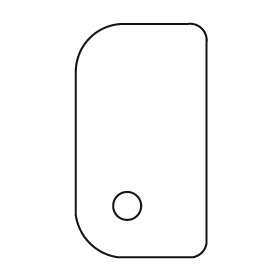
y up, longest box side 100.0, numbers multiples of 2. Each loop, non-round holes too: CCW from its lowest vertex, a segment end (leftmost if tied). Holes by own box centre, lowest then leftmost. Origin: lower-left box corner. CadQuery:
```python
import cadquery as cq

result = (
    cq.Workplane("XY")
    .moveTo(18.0, 0.0)
    .lineTo(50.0, 0.0)
    .threePointArc((54.0, 2.0), (56.0, 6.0))
    .lineTo(56.0, 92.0)
    .threePointArc((54.0, 98.0), (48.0, 100.0))
    .lineTo(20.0, 100.0)
    .threePointArc((6.0, 94.0), (0.0, 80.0))
    .lineTo(0.0, 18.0)
    .threePointArc((6.0, 6.0), (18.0, 0.0))
    .close()
    .moveTo(22.0, 22.0)
    .circle(6.0)
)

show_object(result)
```